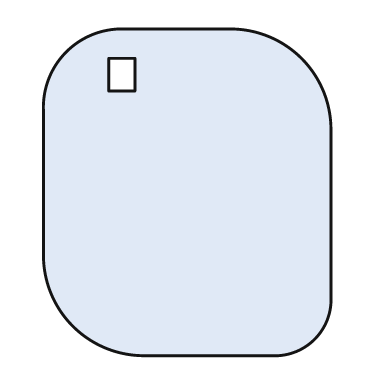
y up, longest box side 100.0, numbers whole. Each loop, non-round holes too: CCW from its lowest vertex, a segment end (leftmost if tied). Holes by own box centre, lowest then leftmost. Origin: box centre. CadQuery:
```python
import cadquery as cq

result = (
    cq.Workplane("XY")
    .moveTo(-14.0, -50.0)
    .lineTo(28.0, -50.0)
    .threePointArc((39.0, -45.0), (44.0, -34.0))
    .lineTo(44.0, 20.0)
    .threePointArc((35.0, 41.0), (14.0, 50.0))
    .lineTo(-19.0, 50.0)
    .threePointArc((-37.0, 43.0), (-44.0, 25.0))
    .lineTo(-44.0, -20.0)
    .threePointArc((-35.0, -41.0), (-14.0, -50.0))
    .close()
    .moveTo(-24.0, 31.0)
    .lineTo(-16.0, 31.0)
    .lineTo(-16.0, 41.0)
    .lineTo(-24.0, 41.0)
    .close()
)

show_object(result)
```